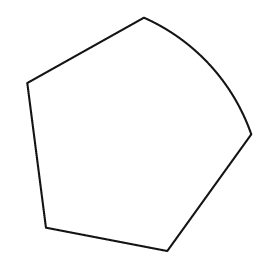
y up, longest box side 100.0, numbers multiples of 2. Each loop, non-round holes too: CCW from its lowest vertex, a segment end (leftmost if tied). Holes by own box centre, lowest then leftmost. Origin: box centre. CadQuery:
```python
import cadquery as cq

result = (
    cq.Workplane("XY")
    .moveTo(12.0, -50.0)
    .lineTo(48.0, 0.0)
    .threePointArc((30.0, 30.0), (2.0, 50.0))
    .lineTo(-48.0, 22.0)
    .lineTo(-40.0, -40.0)
    .close()
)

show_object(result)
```